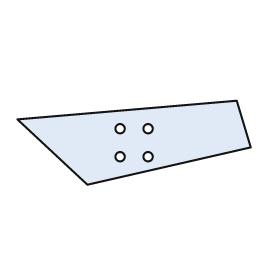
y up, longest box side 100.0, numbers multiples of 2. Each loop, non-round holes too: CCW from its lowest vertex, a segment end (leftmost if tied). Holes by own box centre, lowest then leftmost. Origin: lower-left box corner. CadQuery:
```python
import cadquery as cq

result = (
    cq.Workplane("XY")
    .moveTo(30.0, 0.0)
    .lineTo(100.0, 16.0)
    .lineTo(94.0, 36.0)
    .lineTo(0.0, 28.0)
    .close()
    .moveTo(44.0, 12.0)
    .circle(2.0)
    .moveTo(56.0, 12.0)
    .circle(2.0)
    .moveTo(44.0, 24.0)
    .circle(2.0)
    .moveTo(56.0, 24.0)
    .circle(2.0)
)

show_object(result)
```